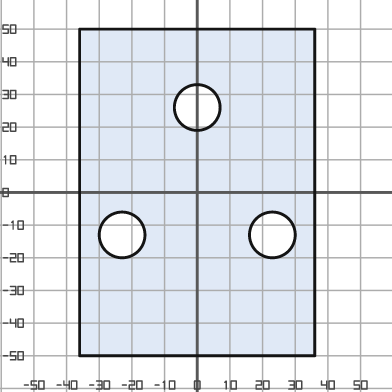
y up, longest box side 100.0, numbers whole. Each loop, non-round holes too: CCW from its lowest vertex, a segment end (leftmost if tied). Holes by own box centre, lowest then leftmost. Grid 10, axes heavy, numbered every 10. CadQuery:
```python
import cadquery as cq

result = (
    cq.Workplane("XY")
    .moveTo(-36.0, -50.0)
    .lineTo(36.0, -50.0)
    .lineTo(36.0, 50.0)
    .lineTo(-36.0, 50.0)
    .close()
    .moveTo(-23.0, -13.0)
    .circle(7.0)
    .moveTo(23.0, -13.0)
    .circle(7.0)
    .moveTo(0.0, 26.0)
    .circle(7.0)
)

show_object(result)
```